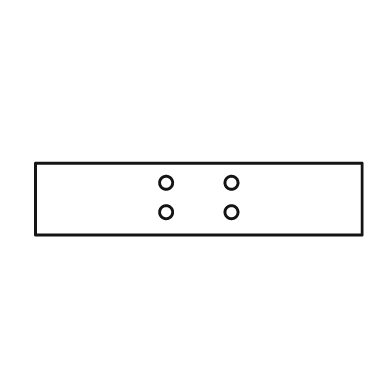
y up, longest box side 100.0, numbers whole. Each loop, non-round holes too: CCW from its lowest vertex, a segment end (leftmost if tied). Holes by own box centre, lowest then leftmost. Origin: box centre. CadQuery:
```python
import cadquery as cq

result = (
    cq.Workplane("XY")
    .moveTo(-50.0, -11.0)
    .lineTo(50.0, -11.0)
    .lineTo(50.0, 11.0)
    .lineTo(-50.0, 11.0)
    .close()
    .moveTo(-10.0, -4.0)
    .circle(2.0)
    .moveTo(10.0, -4.0)
    .circle(2.0)
    .moveTo(-10.0, 5.0)
    .circle(2.0)
    .moveTo(10.0, 5.0)
    .circle(2.0)
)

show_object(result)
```